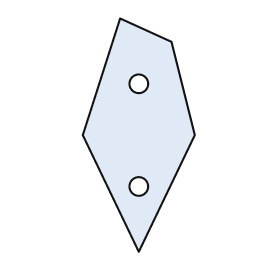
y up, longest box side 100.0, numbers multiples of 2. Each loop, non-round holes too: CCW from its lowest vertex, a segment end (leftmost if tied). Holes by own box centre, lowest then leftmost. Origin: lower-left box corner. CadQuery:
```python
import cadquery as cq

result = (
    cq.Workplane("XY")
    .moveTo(24.0, 0.0)
    .lineTo(48.0, 50.0)
    .lineTo(38.0, 90.0)
    .lineTo(16.0, 100.0)
    .lineTo(0.0, 50.0)
    .close()
    .moveTo(24.0, 28.0)
    .circle(4.0)
    .moveTo(24.0, 72.0)
    .circle(4.0)
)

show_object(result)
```